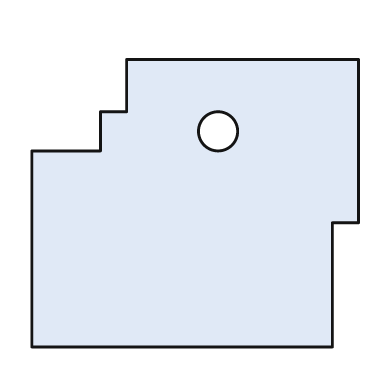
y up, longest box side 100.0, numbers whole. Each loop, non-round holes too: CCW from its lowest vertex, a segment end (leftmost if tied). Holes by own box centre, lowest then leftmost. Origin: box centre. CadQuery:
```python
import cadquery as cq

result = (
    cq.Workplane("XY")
    .moveTo(-50.0, -44.0)
    .lineTo(42.0, -44.0)
    .lineTo(42.0, -6.0)
    .lineTo(50.0, -6.0)
    .lineTo(50.0, 44.0)
    .lineTo(-21.0, 44.0)
    .lineTo(-21.0, 28.0)
    .lineTo(-29.0, 28.0)
    .lineTo(-29.0, 16.0)
    .lineTo(-50.0, 16.0)
    .close()
    .moveTo(7.0, 22.0)
    .circle(6.0)
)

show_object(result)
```